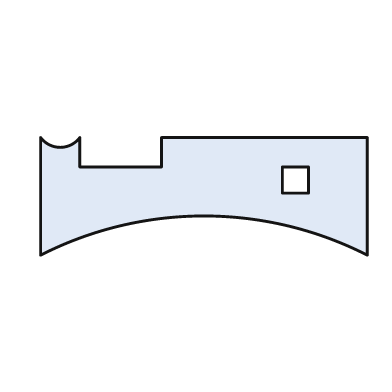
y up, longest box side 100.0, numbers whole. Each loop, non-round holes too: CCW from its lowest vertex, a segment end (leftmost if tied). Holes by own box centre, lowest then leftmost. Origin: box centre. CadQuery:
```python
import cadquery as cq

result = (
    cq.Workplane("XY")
    .moveTo(-50.0, -18.0)
    .threePointArc((0.0, -6.0), (50.0, -18.0))
    .lineTo(50.0, 18.0)
    .lineTo(-13.0, 18.0)
    .lineTo(-13.0, 9.0)
    .lineTo(-38.0, 9.0)
    .lineTo(-38.0, 18.0)
    .threePointArc((-44.0, 15.0), (-50.0, 18.0))
    .close()
    .moveTo(24.0, 1.0)
    .lineTo(32.0, 1.0)
    .lineTo(32.0, 9.0)
    .lineTo(24.0, 9.0)
    .close()
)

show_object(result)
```